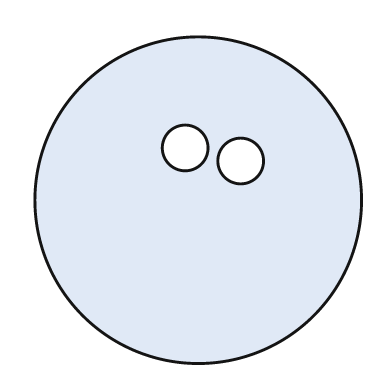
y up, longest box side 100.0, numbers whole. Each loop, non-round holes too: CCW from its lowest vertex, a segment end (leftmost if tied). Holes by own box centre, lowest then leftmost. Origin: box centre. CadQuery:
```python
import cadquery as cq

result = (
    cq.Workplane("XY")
    .moveTo(0.0, 0.0)
    .circle(50.0)
    .moveTo(13.0, 12.0)
    .circle(7.0)
    .moveTo(-4.0, 16.0)
    .circle(7.0)
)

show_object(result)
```